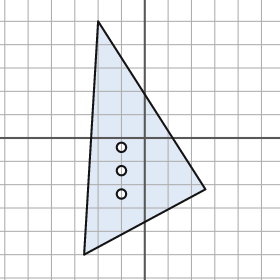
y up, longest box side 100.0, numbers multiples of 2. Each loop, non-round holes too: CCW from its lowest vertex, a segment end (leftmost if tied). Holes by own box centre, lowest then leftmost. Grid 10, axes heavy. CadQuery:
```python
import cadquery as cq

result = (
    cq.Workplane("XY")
    .moveTo(-26.0, -50.0)
    .lineTo(26.0, -22.0)
    .lineTo(-20.0, 50.0)
    .close()
    .moveTo(-10.0, -24.0)
    .circle(2.0)
    .moveTo(-10.0, -14.0)
    .circle(2.0)
    .moveTo(-10.0, -4.0)
    .circle(2.0)
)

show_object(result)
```